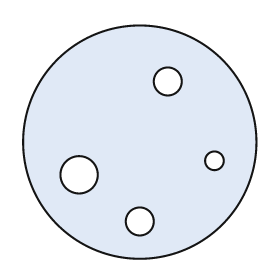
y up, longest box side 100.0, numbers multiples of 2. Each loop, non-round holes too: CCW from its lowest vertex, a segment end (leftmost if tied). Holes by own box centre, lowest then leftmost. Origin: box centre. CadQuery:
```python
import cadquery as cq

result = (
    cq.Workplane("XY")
    .moveTo(0.0, 0.0)
    .circle(50.0)
    .moveTo(0.0, -34.0)
    .circle(6.0)
    .moveTo(-26.0, -14.0)
    .circle(8.0)
    .moveTo(32.0, -8.0)
    .circle(4.0)
    .moveTo(12.0, 26.0)
    .circle(6.0)
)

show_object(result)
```